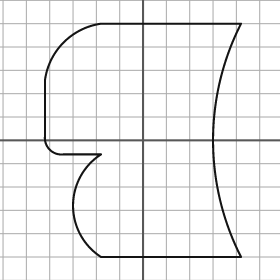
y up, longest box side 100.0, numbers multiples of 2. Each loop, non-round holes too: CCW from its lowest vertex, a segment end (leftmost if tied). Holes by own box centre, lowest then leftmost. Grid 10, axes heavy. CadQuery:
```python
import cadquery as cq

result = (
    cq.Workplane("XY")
    .moveTo(-18.0, -50.0)
    .lineTo(42.0, -50.0)
    .threePointArc((30.0, 0.0), (42.0, 50.0))
    .lineTo(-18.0, 50.0)
    .threePointArc((-34.0, 42.0), (-42.0, 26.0))
    .lineTo(-42.0, 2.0)
    .threePointArc((-40.0, -4.0), (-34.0, -6.0))
    .lineTo(-18.0, -6.0)
    .threePointArc((-30.0, -28.0), (-18.0, -50.0))
    .close()
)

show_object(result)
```